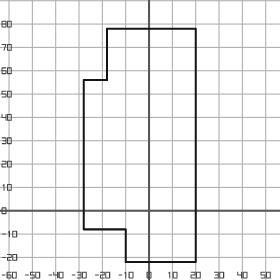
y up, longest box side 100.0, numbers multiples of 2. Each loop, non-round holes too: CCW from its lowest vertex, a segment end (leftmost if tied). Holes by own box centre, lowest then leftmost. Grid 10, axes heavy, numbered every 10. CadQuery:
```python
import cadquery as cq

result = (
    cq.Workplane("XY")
    .moveTo(-10.0, -22.0)
    .lineTo(20.0, -22.0)
    .lineTo(20.0, 78.0)
    .lineTo(-18.0, 78.0)
    .lineTo(-18.0, 56.0)
    .lineTo(-28.0, 56.0)
    .lineTo(-28.0, -8.0)
    .lineTo(-10.0, -8.0)
    .close()
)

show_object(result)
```